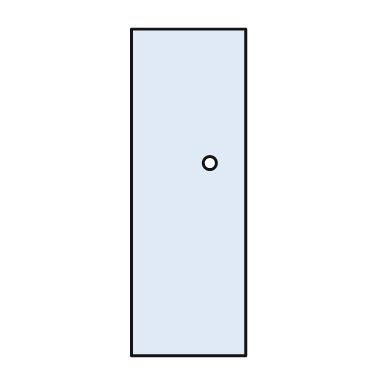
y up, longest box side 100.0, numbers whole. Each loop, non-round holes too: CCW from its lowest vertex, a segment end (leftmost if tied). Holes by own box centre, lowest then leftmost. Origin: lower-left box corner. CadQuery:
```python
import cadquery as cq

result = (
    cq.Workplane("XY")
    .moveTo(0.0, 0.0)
    .lineTo(35.0, 0.0)
    .lineTo(35.0, 100.0)
    .lineTo(0.0, 100.0)
    .close()
    .moveTo(24.0, 59.0)
    .circle(2.0)
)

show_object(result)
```